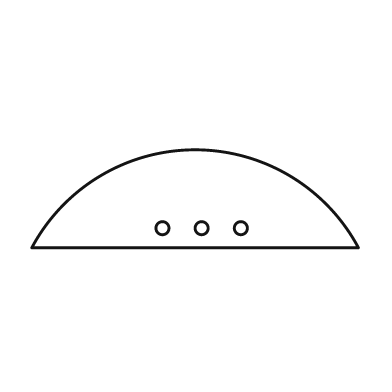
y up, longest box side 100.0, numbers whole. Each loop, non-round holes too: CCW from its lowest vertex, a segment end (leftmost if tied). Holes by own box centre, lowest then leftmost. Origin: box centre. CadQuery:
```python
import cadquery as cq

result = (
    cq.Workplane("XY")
    .moveTo(-50.0, -15.0)
    .lineTo(50.0, -15.0)
    .threePointArc((0.0, 15.0), (-50.0, -15.0))
    .close()
    .moveTo(-10.0, -9.0)
    .circle(2.0)
    .moveTo(2.0, -9.0)
    .circle(2.0)
    .moveTo(14.0, -9.0)
    .circle(2.0)
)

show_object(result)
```